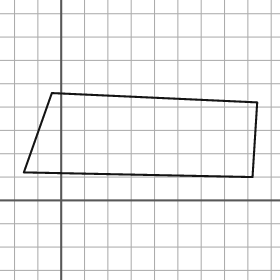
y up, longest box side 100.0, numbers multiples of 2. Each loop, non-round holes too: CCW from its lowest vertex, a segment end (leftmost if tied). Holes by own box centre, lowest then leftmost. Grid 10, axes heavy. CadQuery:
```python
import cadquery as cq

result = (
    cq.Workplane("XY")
    .moveTo(82.0, 10.0)
    .lineTo(84.0, 42.0)
    .lineTo(-4.0, 46.0)
    .lineTo(-16.0, 12.0)
    .close()
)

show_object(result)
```